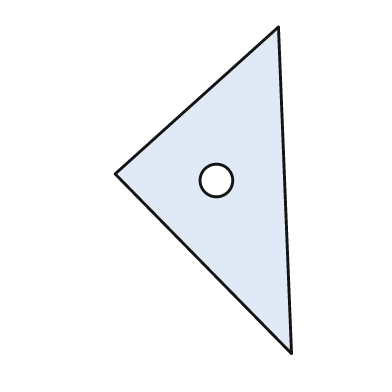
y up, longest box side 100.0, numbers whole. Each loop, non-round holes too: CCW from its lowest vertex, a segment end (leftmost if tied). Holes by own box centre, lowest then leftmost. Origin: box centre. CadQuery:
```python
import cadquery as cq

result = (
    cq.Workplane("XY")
    .moveTo(27.0, -50.0)
    .lineTo(23.0, 50.0)
    .lineTo(-27.0, 5.0)
    .close()
    .moveTo(4.0, 3.0)
    .circle(5.0)
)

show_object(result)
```